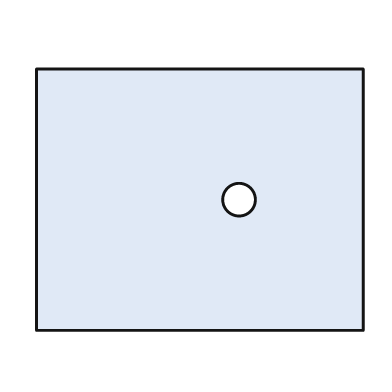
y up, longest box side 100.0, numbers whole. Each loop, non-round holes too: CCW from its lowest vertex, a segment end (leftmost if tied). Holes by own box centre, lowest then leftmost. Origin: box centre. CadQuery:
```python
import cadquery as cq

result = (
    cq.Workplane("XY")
    .moveTo(-50.0, -40.0)
    .lineTo(50.0, -40.0)
    .lineTo(50.0, 40.0)
    .lineTo(-50.0, 40.0)
    .close()
    .moveTo(12.0, 0.0)
    .circle(5.0)
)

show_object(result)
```